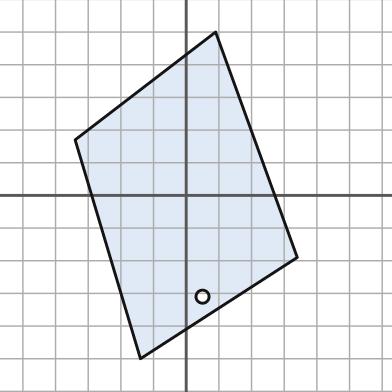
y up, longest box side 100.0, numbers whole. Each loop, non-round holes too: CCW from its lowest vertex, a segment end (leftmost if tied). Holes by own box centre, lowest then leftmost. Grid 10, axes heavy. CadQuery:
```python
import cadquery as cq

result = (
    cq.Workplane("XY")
    .moveTo(-14.0, -50.0)
    .lineTo(34.0, -19.0)
    .lineTo(9.0, 50.0)
    .lineTo(-34.0, 17.0)
    .close()
    .moveTo(5.0, -31.0)
    .circle(2.0)
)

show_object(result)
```